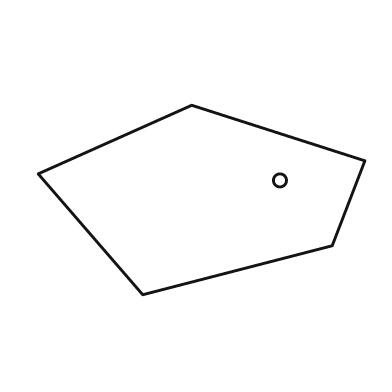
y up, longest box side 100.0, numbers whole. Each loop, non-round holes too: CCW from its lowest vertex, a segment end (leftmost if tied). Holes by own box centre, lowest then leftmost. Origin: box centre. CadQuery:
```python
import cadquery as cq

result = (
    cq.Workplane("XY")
    .moveTo(-18.0, -29.0)
    .lineTo(40.0, -14.0)
    .lineTo(50.0, 12.0)
    .lineTo(-3.0, 29.0)
    .lineTo(-50.0, 8.0)
    .close()
    .moveTo(24.0, 6.0)
    .circle(2.0)
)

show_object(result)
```